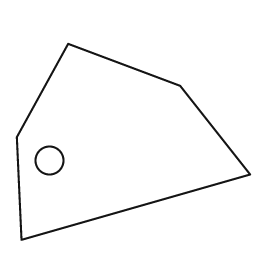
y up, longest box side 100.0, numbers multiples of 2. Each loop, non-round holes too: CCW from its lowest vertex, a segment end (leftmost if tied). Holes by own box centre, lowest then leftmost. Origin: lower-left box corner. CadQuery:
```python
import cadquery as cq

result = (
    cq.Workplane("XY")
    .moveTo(2.0, 0.0)
    .lineTo(100.0, 28.0)
    .lineTo(70.0, 66.0)
    .lineTo(22.0, 84.0)
    .lineTo(0.0, 44.0)
    .close()
    .moveTo(14.0, 34.0)
    .circle(6.0)
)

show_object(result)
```